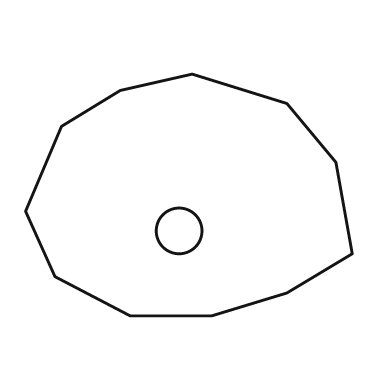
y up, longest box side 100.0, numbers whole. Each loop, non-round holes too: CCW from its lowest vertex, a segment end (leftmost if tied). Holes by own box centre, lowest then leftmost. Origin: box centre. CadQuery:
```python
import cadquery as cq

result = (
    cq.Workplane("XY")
    .moveTo(-18.0, -37.0)
    .lineTo(7.0, -37.0)
    .lineTo(30.0, -30.0)
    .lineTo(50.0, -18.0)
    .lineTo(45.0, 10.0)
    .lineTo(30.0, 28.0)
    .lineTo(1.0, 37.0)
    .lineTo(-21.0, 32.0)
    .lineTo(-39.0, 21.0)
    .lineTo(-50.0, -5.0)
    .lineTo(-41.0, -25.0)
    .close()
    .moveTo(-3.0, -11.0)
    .circle(7.0)
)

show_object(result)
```